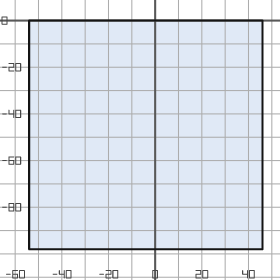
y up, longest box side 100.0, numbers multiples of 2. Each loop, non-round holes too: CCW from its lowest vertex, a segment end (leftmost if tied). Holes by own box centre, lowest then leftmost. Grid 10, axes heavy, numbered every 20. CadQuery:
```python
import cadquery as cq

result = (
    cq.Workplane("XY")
    .moveTo(-54.0, -98.0)
    .lineTo(46.0, -98.0)
    .lineTo(46.0, 0.0)
    .lineTo(-54.0, 0.0)
    .close()
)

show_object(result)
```